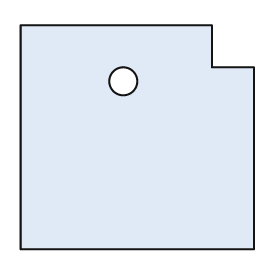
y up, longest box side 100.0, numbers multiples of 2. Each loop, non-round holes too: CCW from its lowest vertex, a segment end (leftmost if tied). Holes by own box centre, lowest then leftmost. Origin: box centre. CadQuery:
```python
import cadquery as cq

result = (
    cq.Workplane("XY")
    .moveTo(-50.0, -48.0)
    .lineTo(50.0, -48.0)
    .lineTo(50.0, 30.0)
    .lineTo(32.0, 30.0)
    .lineTo(32.0, 48.0)
    .lineTo(-50.0, 48.0)
    .close()
    .moveTo(-6.0, 24.0)
    .circle(6.0)
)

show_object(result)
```